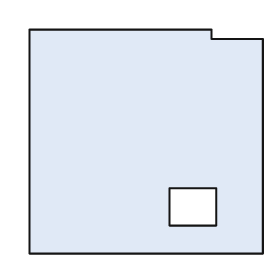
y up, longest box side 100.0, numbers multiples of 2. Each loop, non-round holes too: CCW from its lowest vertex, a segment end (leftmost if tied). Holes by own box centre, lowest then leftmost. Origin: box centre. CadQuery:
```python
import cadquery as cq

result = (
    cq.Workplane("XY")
    .moveTo(-50.0, -48.0)
    .lineTo(50.0, -48.0)
    .lineTo(50.0, 44.0)
    .lineTo(28.0, 44.0)
    .lineTo(28.0, 48.0)
    .lineTo(-50.0, 48.0)
    .close()
    .moveTo(10.0, -36.0)
    .lineTo(30.0, -36.0)
    .lineTo(30.0, -20.0)
    .lineTo(10.0, -20.0)
    .close()
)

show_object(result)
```